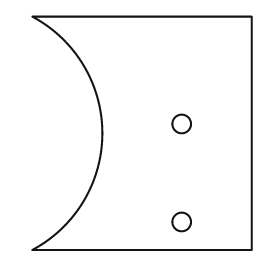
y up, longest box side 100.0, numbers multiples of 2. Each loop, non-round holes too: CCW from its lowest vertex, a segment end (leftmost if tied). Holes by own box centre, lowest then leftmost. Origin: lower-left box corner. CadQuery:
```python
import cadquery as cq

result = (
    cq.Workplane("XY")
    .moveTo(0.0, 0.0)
    .lineTo(94.0, 0.0)
    .lineTo(94.0, 100.0)
    .lineTo(0.0, 100.0)
    .threePointArc((30.0, 50.0), (0.0, 0.0))
    .close()
    .moveTo(64.0, 12.0)
    .circle(4.0)
    .moveTo(64.0, 54.0)
    .circle(4.0)
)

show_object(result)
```